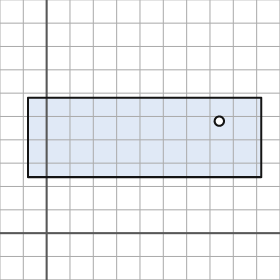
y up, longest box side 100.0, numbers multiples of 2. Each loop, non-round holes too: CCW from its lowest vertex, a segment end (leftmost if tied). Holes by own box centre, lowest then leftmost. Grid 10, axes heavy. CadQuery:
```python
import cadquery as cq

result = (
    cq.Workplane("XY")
    .moveTo(-8.0, 24.0)
    .lineTo(92.0, 24.0)
    .lineTo(92.0, 58.0)
    .lineTo(-8.0, 58.0)
    .close()
    .moveTo(74.0, 48.0)
    .circle(2.0)
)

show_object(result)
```